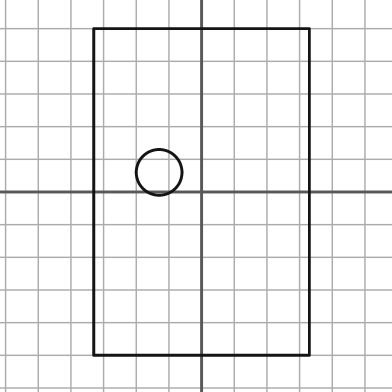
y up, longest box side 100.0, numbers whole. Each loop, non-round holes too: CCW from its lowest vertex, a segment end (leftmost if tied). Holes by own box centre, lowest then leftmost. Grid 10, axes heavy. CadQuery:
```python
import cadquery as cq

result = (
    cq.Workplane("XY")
    .moveTo(-33.0, -50.0)
    .lineTo(33.0, -50.0)
    .lineTo(33.0, 50.0)
    .lineTo(-33.0, 50.0)
    .close()
    .moveTo(-13.0, 6.0)
    .circle(7.0)
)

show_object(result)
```